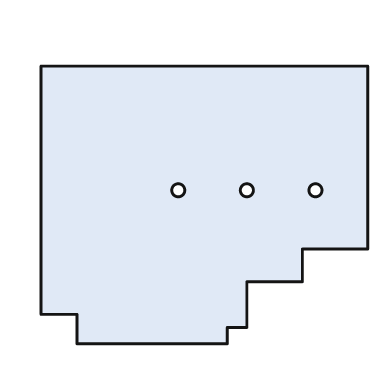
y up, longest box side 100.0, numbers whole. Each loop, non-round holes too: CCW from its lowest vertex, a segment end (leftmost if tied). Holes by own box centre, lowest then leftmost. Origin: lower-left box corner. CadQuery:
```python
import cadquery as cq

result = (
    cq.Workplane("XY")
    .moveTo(11.0, 0.0)
    .lineTo(57.0, 0.0)
    .lineTo(57.0, 5.0)
    .lineTo(63.0, 5.0)
    .lineTo(63.0, 19.0)
    .lineTo(80.0, 19.0)
    .lineTo(80.0, 29.0)
    .lineTo(100.0, 29.0)
    .lineTo(100.0, 85.0)
    .lineTo(0.0, 85.0)
    .lineTo(0.0, 9.0)
    .lineTo(11.0, 9.0)
    .close()
    .moveTo(42.0, 47.0)
    .circle(2.0)
    .moveTo(63.0, 47.0)
    .circle(2.0)
    .moveTo(84.0, 47.0)
    .circle(2.0)
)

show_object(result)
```